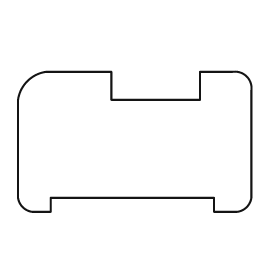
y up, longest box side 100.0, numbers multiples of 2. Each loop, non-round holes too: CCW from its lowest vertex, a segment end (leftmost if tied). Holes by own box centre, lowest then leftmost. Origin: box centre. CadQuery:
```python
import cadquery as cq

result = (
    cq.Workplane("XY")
    .moveTo(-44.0, -30.0)
    .lineTo(-36.0, -30.0)
    .lineTo(-36.0, -24.0)
    .lineTo(34.0, -24.0)
    .lineTo(34.0, -30.0)
    .lineTo(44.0, -30.0)
    .threePointArc((48.0, -28.0), (50.0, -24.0))
    .lineTo(50.0, 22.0)
    .threePointArc((48.0, 28.0), (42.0, 30.0))
    .lineTo(28.0, 30.0)
    .lineTo(28.0, 18.0)
    .lineTo(-10.0, 18.0)
    .lineTo(-10.0, 30.0)
    .lineTo(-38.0, 30.0)
    .threePointArc((-46.0, 26.0), (-50.0, 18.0))
    .lineTo(-50.0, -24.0)
    .threePointArc((-48.0, -28.0), (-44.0, -30.0))
    .close()
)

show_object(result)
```